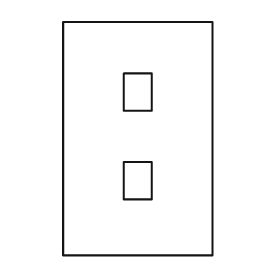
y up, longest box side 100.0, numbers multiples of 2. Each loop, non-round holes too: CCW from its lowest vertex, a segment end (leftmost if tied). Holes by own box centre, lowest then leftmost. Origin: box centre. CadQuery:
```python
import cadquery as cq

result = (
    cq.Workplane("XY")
    .moveTo(-32.0, -50.0)
    .lineTo(32.0, -50.0)
    .lineTo(32.0, 50.0)
    .lineTo(-32.0, 50.0)
    .close()
    .moveTo(-6.0, -26.0)
    .lineTo(6.0, -26.0)
    .lineTo(6.0, -10.0)
    .lineTo(-6.0, -10.0)
    .close()
    .moveTo(-6.0, 12.0)
    .lineTo(6.0, 12.0)
    .lineTo(6.0, 28.0)
    .lineTo(-6.0, 28.0)
    .close()
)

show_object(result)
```